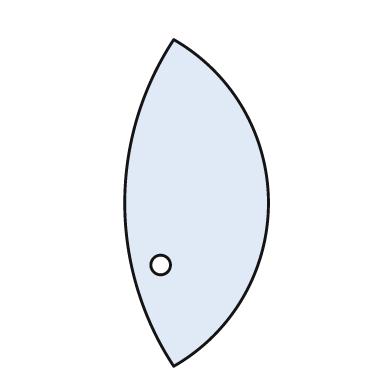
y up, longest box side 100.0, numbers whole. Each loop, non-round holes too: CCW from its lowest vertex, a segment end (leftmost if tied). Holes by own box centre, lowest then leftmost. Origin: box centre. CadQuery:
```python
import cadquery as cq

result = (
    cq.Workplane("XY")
    .moveTo(-7.0, -50.0)
    .threePointArc((22.0, 0.0), (-7.0, 50.0))
    .threePointArc((-22.0, 0.0), (-7.0, -50.0))
    .close()
    .moveTo(-11.0, -19.0)
    .circle(3.0)
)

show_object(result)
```